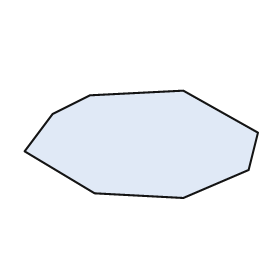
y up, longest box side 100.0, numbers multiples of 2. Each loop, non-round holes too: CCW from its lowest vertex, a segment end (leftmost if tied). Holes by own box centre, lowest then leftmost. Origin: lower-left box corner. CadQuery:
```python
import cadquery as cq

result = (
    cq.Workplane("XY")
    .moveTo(68.0, 0.0)
    .lineTo(96.0, 12.0)
    .lineTo(100.0, 28.0)
    .lineTo(68.0, 46.0)
    .lineTo(28.0, 44.0)
    .lineTo(12.0, 36.0)
    .lineTo(0.0, 20.0)
    .lineTo(30.0, 2.0)
    .close()
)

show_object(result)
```